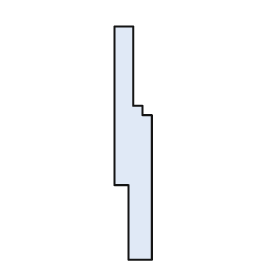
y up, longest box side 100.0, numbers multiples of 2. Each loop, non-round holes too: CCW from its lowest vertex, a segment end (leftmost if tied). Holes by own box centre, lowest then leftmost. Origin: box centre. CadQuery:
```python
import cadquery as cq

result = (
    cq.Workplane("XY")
    .moveTo(-2.0, -50.0)
    .lineTo(8.0, -50.0)
    .lineTo(8.0, 12.0)
    .lineTo(4.0, 12.0)
    .lineTo(4.0, 16.0)
    .lineTo(0.0, 16.0)
    .lineTo(0.0, 50.0)
    .lineTo(-8.0, 50.0)
    .lineTo(-8.0, -18.0)
    .lineTo(-2.0, -18.0)
    .close()
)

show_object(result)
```